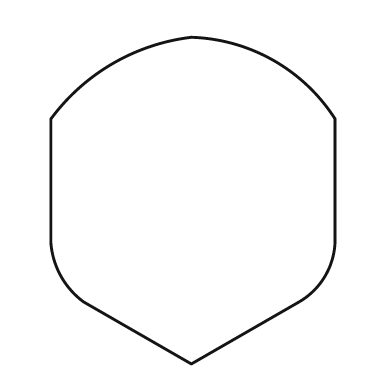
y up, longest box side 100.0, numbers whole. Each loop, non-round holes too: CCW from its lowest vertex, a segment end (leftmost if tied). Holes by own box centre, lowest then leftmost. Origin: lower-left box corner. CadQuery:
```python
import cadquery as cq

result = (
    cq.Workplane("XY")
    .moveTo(43.0, 0.0)
    .lineTo(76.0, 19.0)
    .threePointArc((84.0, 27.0), (87.0, 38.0))
    .lineTo(87.0, 75.0)
    .threePointArc((68.0, 93.0), (43.0, 100.0))
    .threePointArc((19.0, 92.0), (0.0, 75.0))
    .lineTo(0.0, 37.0)
    .threePointArc((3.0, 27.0), (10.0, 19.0))
    .close()
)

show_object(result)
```